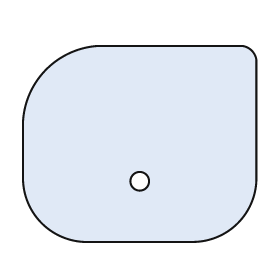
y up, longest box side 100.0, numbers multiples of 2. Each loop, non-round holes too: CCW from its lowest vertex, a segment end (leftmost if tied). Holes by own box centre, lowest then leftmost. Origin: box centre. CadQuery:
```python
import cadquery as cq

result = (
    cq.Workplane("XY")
    .moveTo(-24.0, -42.0)
    .lineTo(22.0, -42.0)
    .threePointArc((42.0, -34.0), (50.0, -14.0))
    .lineTo(50.0, 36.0)
    .threePointArc((48.0, 40.0), (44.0, 42.0))
    .lineTo(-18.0, 42.0)
    .threePointArc((-40.0, 32.0), (-50.0, 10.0))
    .lineTo(-50.0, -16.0)
    .threePointArc((-42.0, -34.0), (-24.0, -42.0))
    .close()
    .moveTo(0.0, -16.0)
    .circle(4.0)
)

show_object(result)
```